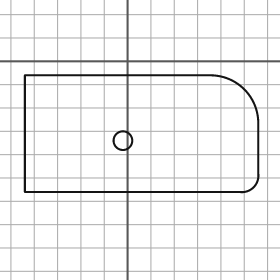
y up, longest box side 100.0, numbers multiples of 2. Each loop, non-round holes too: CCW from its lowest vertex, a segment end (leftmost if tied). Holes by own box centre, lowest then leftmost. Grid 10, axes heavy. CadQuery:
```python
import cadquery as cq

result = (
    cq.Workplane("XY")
    .moveTo(-44.0, -56.0)
    .lineTo(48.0, -56.0)
    .threePointArc((54.0, -54.0), (56.0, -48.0))
    .lineTo(56.0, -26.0)
    .threePointArc((50.0, -12.0), (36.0, -6.0))
    .lineTo(-44.0, -6.0)
    .close()
    .moveTo(-2.0, -34.0)
    .circle(4.0)
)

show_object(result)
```